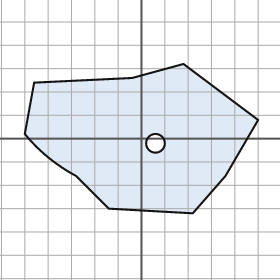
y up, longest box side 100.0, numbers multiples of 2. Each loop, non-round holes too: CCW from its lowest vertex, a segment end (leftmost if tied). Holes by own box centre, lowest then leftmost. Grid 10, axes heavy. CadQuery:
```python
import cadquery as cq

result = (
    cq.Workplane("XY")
    .moveTo(22.0, -32.0)
    .lineTo(36.0, -16.0)
    .lineTo(50.0, 8.0)
    .lineTo(18.0, 32.0)
    .lineTo(-4.0, 26.0)
    .lineTo(-46.0, 24.0)
    .lineTo(-50.0, 2.0)
    .threePointArc((-40.0, -8.0), (-28.0, -16.0))
    .lineTo(-14.0, -30.0)
    .close()
    .moveTo(6.0, -2.0)
    .circle(4.0)
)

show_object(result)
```